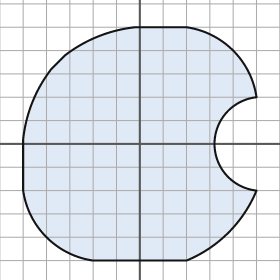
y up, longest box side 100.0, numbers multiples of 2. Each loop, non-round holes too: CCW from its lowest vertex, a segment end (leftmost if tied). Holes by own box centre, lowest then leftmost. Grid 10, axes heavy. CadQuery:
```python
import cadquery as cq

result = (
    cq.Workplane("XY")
    .moveTo(-20.0, -50.0)
    .lineTo(20.0, -50.0)
    .threePointArc((38.0, -38.0), (50.0, -20.0))
    .threePointArc((32.0, 0.0), (50.0, 20.0))
    .threePointArc((40.0, 40.0), (20.0, 50.0))
    .lineTo(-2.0, 50.0)
    .threePointArc((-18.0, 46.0), (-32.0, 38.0))
    .lineTo(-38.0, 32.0)
    .threePointArc((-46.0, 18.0), (-50.0, 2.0))
    .lineTo(-50.0, -20.0)
    .threePointArc((-40.0, -40.0), (-20.0, -50.0))
    .close()
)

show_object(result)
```